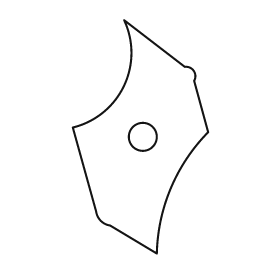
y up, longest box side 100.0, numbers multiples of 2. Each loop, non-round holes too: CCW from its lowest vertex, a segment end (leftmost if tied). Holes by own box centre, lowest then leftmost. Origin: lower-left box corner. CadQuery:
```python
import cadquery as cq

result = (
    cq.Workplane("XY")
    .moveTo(36.0, 0.0)
    .threePointArc((42.0, 28.0), (58.0, 52.0))
    .lineTo(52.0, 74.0)
    .threePointArc((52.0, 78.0), (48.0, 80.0))
    .lineTo(22.0, 100.0)
    .threePointArc((22.0, 72.0), (0.0, 54.0))
    .lineTo(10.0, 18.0)
    .threePointArc((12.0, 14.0), (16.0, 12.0))
    .close()
    .moveTo(30.0, 50.0)
    .circle(6.0)
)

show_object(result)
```